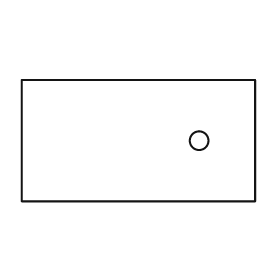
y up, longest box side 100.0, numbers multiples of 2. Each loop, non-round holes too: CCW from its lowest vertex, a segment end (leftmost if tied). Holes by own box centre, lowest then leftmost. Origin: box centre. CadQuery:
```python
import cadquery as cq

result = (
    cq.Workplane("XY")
    .moveTo(-50.0, -26.0)
    .lineTo(50.0, -26.0)
    .lineTo(50.0, 26.0)
    .lineTo(-50.0, 26.0)
    .close()
    .moveTo(26.0, 0.0)
    .circle(4.0)
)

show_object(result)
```